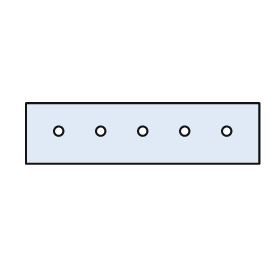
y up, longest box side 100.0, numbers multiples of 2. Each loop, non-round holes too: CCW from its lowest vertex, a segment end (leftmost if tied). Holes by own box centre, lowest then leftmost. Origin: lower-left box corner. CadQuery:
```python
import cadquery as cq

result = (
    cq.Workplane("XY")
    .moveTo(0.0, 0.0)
    .lineTo(100.0, 0.0)
    .lineTo(100.0, 26.0)
    .lineTo(0.0, 26.0)
    .close()
    .moveTo(14.0, 14.0)
    .circle(2.0)
    .moveTo(32.0, 14.0)
    .circle(2.0)
    .moveTo(50.0, 14.0)
    .circle(2.0)
    .moveTo(68.0, 14.0)
    .circle(2.0)
    .moveTo(86.0, 14.0)
    .circle(2.0)
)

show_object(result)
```